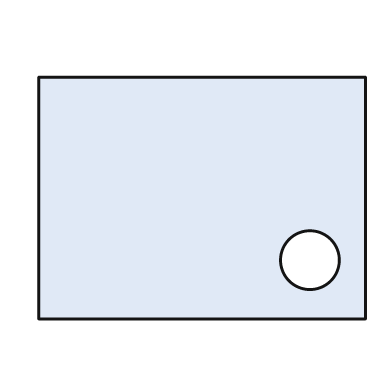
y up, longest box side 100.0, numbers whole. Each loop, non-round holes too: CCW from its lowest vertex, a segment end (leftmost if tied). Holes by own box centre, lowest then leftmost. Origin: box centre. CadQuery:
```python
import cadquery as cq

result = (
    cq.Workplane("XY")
    .moveTo(-50.0, -37.0)
    .lineTo(50.0, -37.0)
    .lineTo(50.0, 37.0)
    .lineTo(-50.0, 37.0)
    .close()
    .moveTo(33.0, -19.0)
    .circle(9.0)
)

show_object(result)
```